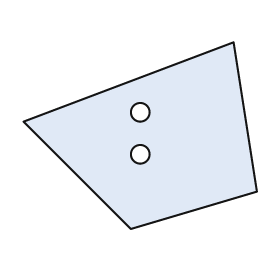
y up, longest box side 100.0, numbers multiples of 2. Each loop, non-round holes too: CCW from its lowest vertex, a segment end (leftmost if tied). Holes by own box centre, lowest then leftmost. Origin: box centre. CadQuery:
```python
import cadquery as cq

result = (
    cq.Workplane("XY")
    .moveTo(-4.0, -40.0)
    .lineTo(50.0, -24.0)
    .lineTo(40.0, 40.0)
    .lineTo(-50.0, 6.0)
    .close()
    .moveTo(0.0, -8.0)
    .circle(4.0)
    .moveTo(0.0, 10.0)
    .circle(4.0)
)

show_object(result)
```